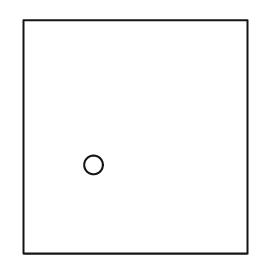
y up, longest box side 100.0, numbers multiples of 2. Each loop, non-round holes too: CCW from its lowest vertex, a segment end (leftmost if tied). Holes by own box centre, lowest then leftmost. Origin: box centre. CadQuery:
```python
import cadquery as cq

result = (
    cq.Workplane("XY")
    .moveTo(-48.0, -50.0)
    .lineTo(48.0, -50.0)
    .lineTo(48.0, 50.0)
    .lineTo(-48.0, 50.0)
    .close()
    .moveTo(-18.0, -12.0)
    .circle(4.0)
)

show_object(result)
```